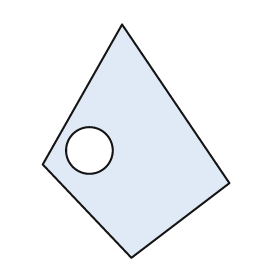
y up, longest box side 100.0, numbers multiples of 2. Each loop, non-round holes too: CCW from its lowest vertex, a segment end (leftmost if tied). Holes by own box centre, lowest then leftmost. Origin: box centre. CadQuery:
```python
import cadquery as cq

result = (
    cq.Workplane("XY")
    .moveTo(-2.0, -50.0)
    .lineTo(40.0, -18.0)
    .lineTo(-6.0, 50.0)
    .lineTo(-40.0, -10.0)
    .close()
    .moveTo(-20.0, -4.0)
    .circle(10.0)
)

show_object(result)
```